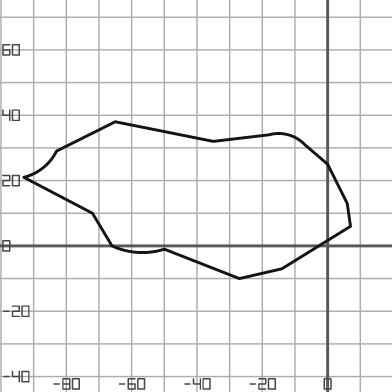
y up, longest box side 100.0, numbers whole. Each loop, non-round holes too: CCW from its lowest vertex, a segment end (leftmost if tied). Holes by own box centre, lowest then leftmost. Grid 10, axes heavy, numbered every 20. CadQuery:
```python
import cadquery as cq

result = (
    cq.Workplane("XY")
    .moveTo(-27.0, -10.0)
    .lineTo(-14.0, -7.0)
    .lineTo(7.0, 6.0)
    .lineTo(6.0, 13.0)
    .lineTo(0.0, 25.0)
    .lineTo(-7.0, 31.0)
    .threePointArc((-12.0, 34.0), (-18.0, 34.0))
    .lineTo(-35.0, 32.0)
    .lineTo(-65.0, 38.0)
    .lineTo(-83.0, 29.0)
    .threePointArc((-87.0, 24.0), (-93.0, 21.0))
    .lineTo(-72.0, 10.0)
    .lineTo(-66.0, 0.0)
    .threePointArc((-58.0, -2.0), (-50.0, -1.0))
    .close()
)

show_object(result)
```